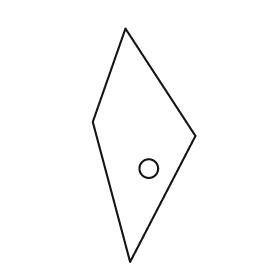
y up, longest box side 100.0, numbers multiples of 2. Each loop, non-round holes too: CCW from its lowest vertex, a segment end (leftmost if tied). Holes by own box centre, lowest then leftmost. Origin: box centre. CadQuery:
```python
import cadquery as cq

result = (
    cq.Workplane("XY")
    .moveTo(-6.0, -50.0)
    .lineTo(22.0, 4.0)
    .lineTo(-8.0, 50.0)
    .lineTo(-22.0, 10.0)
    .close()
    .moveTo(2.0, -10.0)
    .circle(4.0)
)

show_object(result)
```